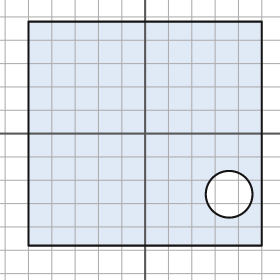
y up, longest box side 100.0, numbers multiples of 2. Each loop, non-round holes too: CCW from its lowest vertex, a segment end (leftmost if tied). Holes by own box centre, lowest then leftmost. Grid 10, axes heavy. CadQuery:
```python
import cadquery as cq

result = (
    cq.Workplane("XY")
    .moveTo(-50.0, -48.0)
    .lineTo(50.0, -48.0)
    .lineTo(50.0, 48.0)
    .lineTo(-50.0, 48.0)
    .close()
    .moveTo(36.0, -26.0)
    .circle(10.0)
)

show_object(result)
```